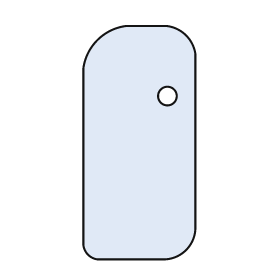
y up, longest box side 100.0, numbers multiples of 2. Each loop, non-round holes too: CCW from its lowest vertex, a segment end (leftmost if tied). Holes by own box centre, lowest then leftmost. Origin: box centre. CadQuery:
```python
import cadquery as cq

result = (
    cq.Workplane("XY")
    .moveTo(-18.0, -50.0)
    .lineTo(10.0, -50.0)
    .threePointArc((20.0, -46.0), (24.0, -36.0))
    .lineTo(24.0, 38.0)
    .threePointArc((20.0, 46.0), (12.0, 50.0))
    .lineTo(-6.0, 50.0)
    .threePointArc((-18.0, 44.0), (-24.0, 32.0))
    .lineTo(-24.0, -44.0)
    .threePointArc((-22.0, -48.0), (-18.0, -50.0))
    .close()
    .moveTo(12.0, 20.0)
    .circle(4.0)
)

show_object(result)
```